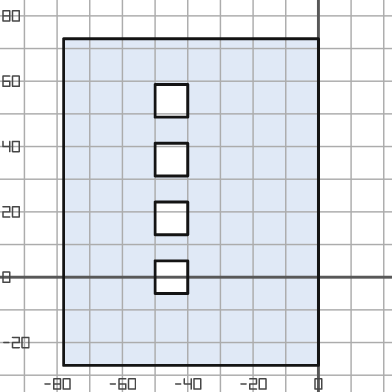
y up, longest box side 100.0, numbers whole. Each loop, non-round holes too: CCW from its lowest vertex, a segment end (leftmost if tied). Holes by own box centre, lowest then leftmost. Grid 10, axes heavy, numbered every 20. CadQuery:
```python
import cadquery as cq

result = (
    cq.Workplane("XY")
    .moveTo(-78.0, -27.0)
    .lineTo(0.0, -27.0)
    .lineTo(0.0, 73.0)
    .lineTo(-78.0, 73.0)
    .close()
    .moveTo(-50.0, -5.0)
    .lineTo(-40.0, -5.0)
    .lineTo(-40.0, 5.0)
    .lineTo(-50.0, 5.0)
    .close()
    .moveTo(-50.0, 13.0)
    .lineTo(-40.0, 13.0)
    .lineTo(-40.0, 23.0)
    .lineTo(-50.0, 23.0)
    .close()
    .moveTo(-50.0, 31.0)
    .lineTo(-40.0, 31.0)
    .lineTo(-40.0, 41.0)
    .lineTo(-50.0, 41.0)
    .close()
    .moveTo(-50.0, 49.0)
    .lineTo(-40.0, 49.0)
    .lineTo(-40.0, 59.0)
    .lineTo(-50.0, 59.0)
    .close()
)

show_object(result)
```